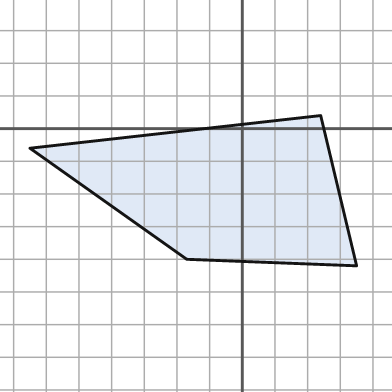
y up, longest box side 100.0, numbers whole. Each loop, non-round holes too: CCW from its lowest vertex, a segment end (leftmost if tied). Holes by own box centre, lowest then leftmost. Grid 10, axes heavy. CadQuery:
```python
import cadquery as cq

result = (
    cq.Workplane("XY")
    .moveTo(35.0, -42.0)
    .lineTo(24.0, 4.0)
    .lineTo(-65.0, -6.0)
    .lineTo(-17.0, -40.0)
    .close()
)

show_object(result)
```